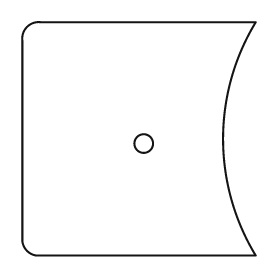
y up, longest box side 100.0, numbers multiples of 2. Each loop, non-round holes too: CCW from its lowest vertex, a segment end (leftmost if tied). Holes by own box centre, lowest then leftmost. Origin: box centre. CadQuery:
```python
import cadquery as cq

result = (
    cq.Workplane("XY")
    .moveTo(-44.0, -50.0)
    .lineTo(50.0, -50.0)
    .threePointArc((36.0, 0.0), (50.0, 50.0))
    .lineTo(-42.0, 50.0)
    .threePointArc((-48.0, 48.0), (-50.0, 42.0))
    .lineTo(-50.0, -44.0)
    .threePointArc((-48.0, -48.0), (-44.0, -50.0))
    .close()
    .moveTo(2.0, -2.0)
    .circle(4.0)
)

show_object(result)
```